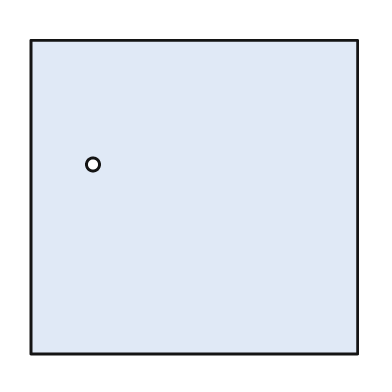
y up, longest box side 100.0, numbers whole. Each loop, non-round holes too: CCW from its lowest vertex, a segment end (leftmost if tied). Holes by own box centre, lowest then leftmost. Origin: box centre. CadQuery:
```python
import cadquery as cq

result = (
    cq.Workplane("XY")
    .moveTo(-50.0, -48.0)
    .lineTo(50.0, -48.0)
    .lineTo(50.0, 48.0)
    .lineTo(-50.0, 48.0)
    .close()
    .moveTo(-31.0, 10.0)
    .circle(2.0)
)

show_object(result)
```